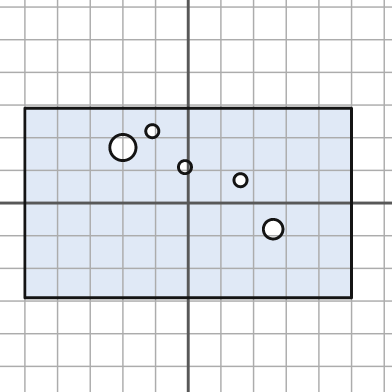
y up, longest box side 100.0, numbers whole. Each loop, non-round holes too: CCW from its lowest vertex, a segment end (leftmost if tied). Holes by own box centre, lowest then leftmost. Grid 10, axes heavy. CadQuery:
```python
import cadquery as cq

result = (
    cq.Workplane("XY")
    .moveTo(-50.0, -29.0)
    .lineTo(50.0, -29.0)
    .lineTo(50.0, 29.0)
    .lineTo(-50.0, 29.0)
    .close()
    .moveTo(26.0, -8.0)
    .circle(3.0)
    .moveTo(16.0, 7.0)
    .circle(2.0)
    .moveTo(-1.0, 11.0)
    .circle(2.0)
    .moveTo(-20.0, 17.0)
    .circle(4.0)
    .moveTo(-11.0, 22.0)
    .circle(2.0)
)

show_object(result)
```